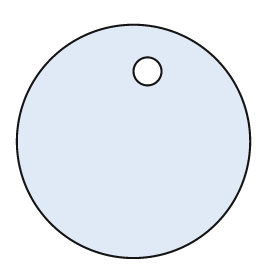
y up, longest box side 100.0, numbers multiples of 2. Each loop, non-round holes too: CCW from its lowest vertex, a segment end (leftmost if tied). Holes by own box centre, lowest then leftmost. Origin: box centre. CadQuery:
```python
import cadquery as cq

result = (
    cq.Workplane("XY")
    .moveTo(0.0, 0.0)
    .circle(50.0)
    .moveTo(6.0, 30.0)
    .circle(6.0)
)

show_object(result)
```